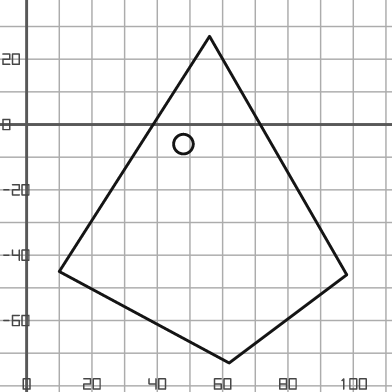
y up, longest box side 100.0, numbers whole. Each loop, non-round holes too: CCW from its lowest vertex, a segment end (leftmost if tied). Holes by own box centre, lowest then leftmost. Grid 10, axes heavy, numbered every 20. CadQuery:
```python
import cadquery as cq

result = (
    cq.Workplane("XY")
    .moveTo(62.0, -73.0)
    .lineTo(98.0, -46.0)
    .lineTo(56.0, 27.0)
    .lineTo(10.0, -45.0)
    .close()
    .moveTo(48.0, -6.0)
    .circle(3.0)
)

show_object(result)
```